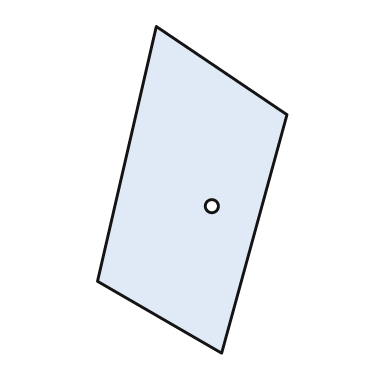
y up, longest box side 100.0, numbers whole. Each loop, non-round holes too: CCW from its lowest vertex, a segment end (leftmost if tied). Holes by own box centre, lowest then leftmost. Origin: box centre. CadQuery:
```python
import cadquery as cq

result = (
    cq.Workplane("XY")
    .moveTo(9.0, -50.0)
    .lineTo(29.0, 23.0)
    .lineTo(-11.0, 50.0)
    .lineTo(-29.0, -28.0)
    .close()
    .moveTo(6.0, -5.0)
    .circle(2.0)
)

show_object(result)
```